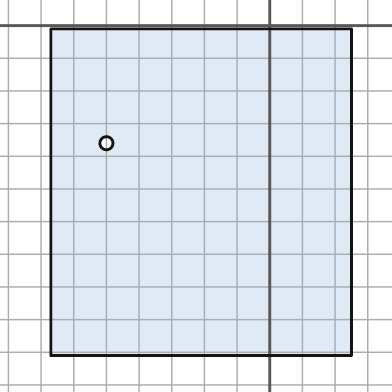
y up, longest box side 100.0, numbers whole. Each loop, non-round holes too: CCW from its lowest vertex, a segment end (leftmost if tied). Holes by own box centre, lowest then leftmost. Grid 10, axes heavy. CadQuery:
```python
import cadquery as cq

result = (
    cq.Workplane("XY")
    .moveTo(-67.0, -101.0)
    .lineTo(25.0, -101.0)
    .lineTo(25.0, -1.0)
    .lineTo(-67.0, -1.0)
    .close()
    .moveTo(-50.0, -36.0)
    .circle(2.0)
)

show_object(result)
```